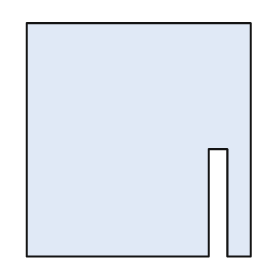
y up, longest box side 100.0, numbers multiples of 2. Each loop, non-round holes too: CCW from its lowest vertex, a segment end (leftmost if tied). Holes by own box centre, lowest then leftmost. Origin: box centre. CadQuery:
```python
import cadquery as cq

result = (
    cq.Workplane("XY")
    .moveTo(-48.0, -50.0)
    .lineTo(30.0, -50.0)
    .lineTo(30.0, -4.0)
    .lineTo(38.0, -4.0)
    .lineTo(38.0, -50.0)
    .lineTo(48.0, -50.0)
    .lineTo(48.0, 50.0)
    .lineTo(-48.0, 50.0)
    .close()
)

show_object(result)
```